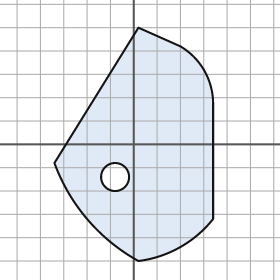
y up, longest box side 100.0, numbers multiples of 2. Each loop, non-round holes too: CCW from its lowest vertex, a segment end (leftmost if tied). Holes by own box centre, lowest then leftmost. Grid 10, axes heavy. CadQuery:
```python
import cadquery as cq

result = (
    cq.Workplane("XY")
    .moveTo(2.0, -50.0)
    .threePointArc((20.0, -44.0), (34.0, -32.0))
    .lineTo(34.0, 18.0)
    .threePointArc((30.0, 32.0), (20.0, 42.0))
    .lineTo(2.0, 50.0)
    .lineTo(-34.0, -8.0)
    .threePointArc((-20.0, -32.0), (2.0, -50.0))
    .close()
    .moveTo(-8.0, -14.0)
    .circle(6.0)
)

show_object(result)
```